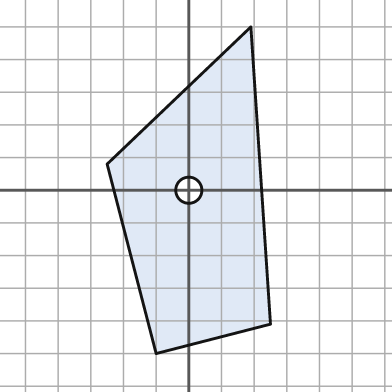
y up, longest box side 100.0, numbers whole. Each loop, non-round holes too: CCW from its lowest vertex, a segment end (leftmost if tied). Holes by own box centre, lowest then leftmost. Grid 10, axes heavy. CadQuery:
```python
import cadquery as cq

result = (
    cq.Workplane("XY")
    .moveTo(-10.0, -50.0)
    .lineTo(25.0, -41.0)
    .lineTo(19.0, 50.0)
    .lineTo(-25.0, 8.0)
    .close()
    .moveTo(0.0, 0.0)
    .circle(4.0)
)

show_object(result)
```